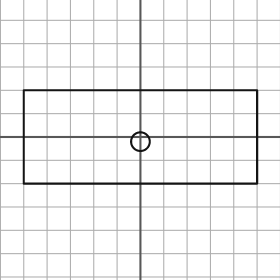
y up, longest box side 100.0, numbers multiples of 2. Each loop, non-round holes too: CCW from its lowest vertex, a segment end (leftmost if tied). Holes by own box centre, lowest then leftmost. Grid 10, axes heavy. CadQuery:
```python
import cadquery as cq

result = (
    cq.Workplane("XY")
    .moveTo(-50.0, -20.0)
    .lineTo(50.0, -20.0)
    .lineTo(50.0, 20.0)
    .lineTo(-50.0, 20.0)
    .close()
    .moveTo(0.0, -2.0)
    .circle(4.0)
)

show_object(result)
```